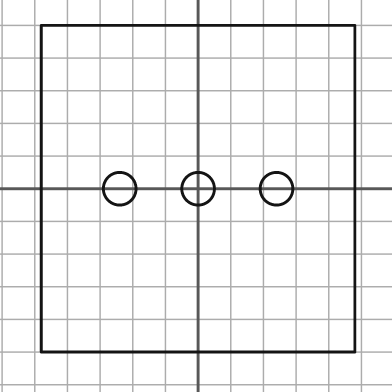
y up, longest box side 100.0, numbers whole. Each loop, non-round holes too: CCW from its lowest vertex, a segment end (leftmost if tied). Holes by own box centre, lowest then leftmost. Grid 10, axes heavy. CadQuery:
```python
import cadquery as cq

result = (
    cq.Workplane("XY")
    .moveTo(-48.0, -50.0)
    .lineTo(48.0, -50.0)
    .lineTo(48.0, 50.0)
    .lineTo(-48.0, 50.0)
    .close()
    .moveTo(-24.0, 0.0)
    .circle(5.0)
    .moveTo(0.0, 0.0)
    .circle(5.0)
    .moveTo(24.0, 0.0)
    .circle(5.0)
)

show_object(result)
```